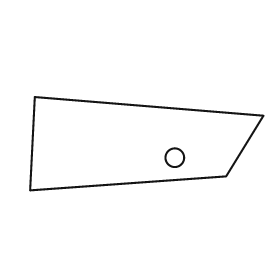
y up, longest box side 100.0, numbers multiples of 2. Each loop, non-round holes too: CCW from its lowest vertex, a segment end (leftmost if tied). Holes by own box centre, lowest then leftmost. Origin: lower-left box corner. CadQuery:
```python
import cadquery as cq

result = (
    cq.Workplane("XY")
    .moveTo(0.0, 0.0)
    .lineTo(84.0, 6.0)
    .lineTo(100.0, 32.0)
    .lineTo(2.0, 40.0)
    .close()
    .moveTo(62.0, 14.0)
    .circle(4.0)
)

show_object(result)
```